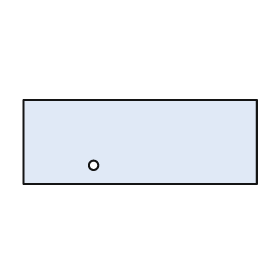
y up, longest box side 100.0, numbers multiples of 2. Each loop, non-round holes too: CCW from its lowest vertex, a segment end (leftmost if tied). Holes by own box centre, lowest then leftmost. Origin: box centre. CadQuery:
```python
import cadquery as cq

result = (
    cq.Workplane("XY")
    .moveTo(-50.0, -18.0)
    .lineTo(50.0, -18.0)
    .lineTo(50.0, 18.0)
    .lineTo(-50.0, 18.0)
    .close()
    .moveTo(-20.0, -10.0)
    .circle(2.0)
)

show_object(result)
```